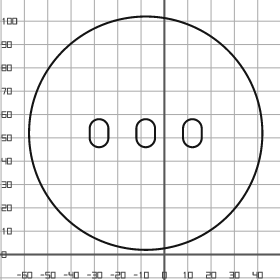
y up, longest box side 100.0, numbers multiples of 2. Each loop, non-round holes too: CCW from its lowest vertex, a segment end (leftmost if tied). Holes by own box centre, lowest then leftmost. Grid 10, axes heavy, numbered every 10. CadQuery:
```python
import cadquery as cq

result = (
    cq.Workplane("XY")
    .moveTo(-8.0, 52.0)
    .circle(50.0)
    .moveTo(-32.0, 50.0)
    .threePointArc((-28.0, 46.0), (-24.0, 50.0))
    .lineTo(-24.0, 54.0)
    .threePointArc((-28.0, 58.0), (-32.0, 54.0))
    .close()
    .moveTo(-12.0, 50.0)
    .threePointArc((-8.0, 46.0), (-4.0, 50.0))
    .lineTo(-4.0, 54.0)
    .threePointArc((-8.0, 58.0), (-12.0, 54.0))
    .close()
    .moveTo(8.0, 50.0)
    .threePointArc((12.0, 46.0), (16.0, 50.0))
    .lineTo(16.0, 54.0)
    .threePointArc((12.0, 58.0), (8.0, 54.0))
    .close()
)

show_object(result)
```